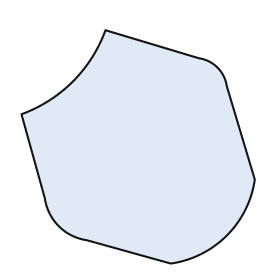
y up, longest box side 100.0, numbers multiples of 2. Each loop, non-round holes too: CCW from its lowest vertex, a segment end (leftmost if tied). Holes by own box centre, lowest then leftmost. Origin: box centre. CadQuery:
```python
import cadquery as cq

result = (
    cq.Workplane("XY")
    .moveTo(14.0, -50.0)
    .threePointArc((38.0, -38.0), (50.0, -14.0))
    .lineTo(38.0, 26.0)
    .threePointArc((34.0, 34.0), (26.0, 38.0))
    .lineTo(-14.0, 50.0)
    .threePointArc((-28.0, 28.0), (-50.0, 14.0))
    .lineTo(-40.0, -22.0)
    .threePointArc((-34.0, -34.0), (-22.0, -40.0))
    .close()
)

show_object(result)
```